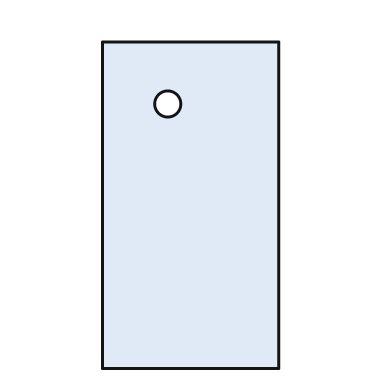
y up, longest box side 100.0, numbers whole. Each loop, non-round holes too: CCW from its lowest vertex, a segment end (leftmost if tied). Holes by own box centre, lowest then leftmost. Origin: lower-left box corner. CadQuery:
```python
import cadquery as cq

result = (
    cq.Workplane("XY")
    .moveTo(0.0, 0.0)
    .lineTo(54.0, 0.0)
    .lineTo(54.0, 100.0)
    .lineTo(0.0, 100.0)
    .close()
    .moveTo(20.0, 81.0)
    .circle(4.0)
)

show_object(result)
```